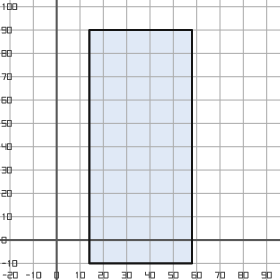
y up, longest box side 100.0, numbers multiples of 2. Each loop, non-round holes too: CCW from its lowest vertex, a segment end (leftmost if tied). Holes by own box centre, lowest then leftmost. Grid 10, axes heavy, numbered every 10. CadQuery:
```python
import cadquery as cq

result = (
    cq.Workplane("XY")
    .moveTo(14.0, -10.0)
    .lineTo(58.0, -10.0)
    .lineTo(58.0, 90.0)
    .lineTo(14.0, 90.0)
    .close()
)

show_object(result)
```